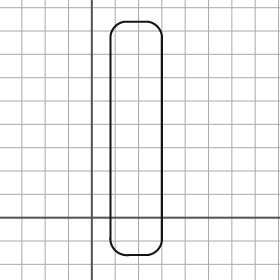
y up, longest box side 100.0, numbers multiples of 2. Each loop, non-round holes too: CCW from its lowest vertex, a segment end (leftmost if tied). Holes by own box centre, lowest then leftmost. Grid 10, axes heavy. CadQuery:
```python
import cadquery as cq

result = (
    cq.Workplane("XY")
    .moveTo(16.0, -16.0)
    .lineTo(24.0, -16.0)
    .threePointArc((28.0, -14.0), (30.0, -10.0))
    .lineTo(30.0, 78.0)
    .threePointArc((28.0, 82.0), (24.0, 84.0))
    .lineTo(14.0, 84.0)
    .threePointArc((10.0, 82.0), (8.0, 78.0))
    .lineTo(8.0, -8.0)
    .threePointArc((10.0, -14.0), (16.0, -16.0))
    .close()
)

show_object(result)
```